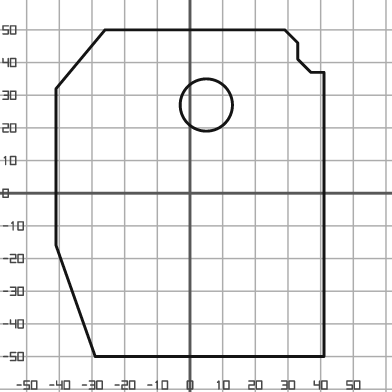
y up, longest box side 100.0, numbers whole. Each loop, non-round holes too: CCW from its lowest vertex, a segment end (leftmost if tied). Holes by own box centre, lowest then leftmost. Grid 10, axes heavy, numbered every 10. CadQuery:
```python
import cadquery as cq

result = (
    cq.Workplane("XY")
    .moveTo(-29.0, -50.0)
    .lineTo(41.0, -50.0)
    .lineTo(41.0, 37.0)
    .lineTo(37.0, 37.0)
    .lineTo(33.0, 41.0)
    .lineTo(33.0, 46.0)
    .lineTo(29.0, 50.0)
    .lineTo(-26.0, 50.0)
    .lineTo(-41.0, 32.0)
    .lineTo(-41.0, -16.0)
    .close()
    .moveTo(5.0, 27.0)
    .circle(8.0)
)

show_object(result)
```